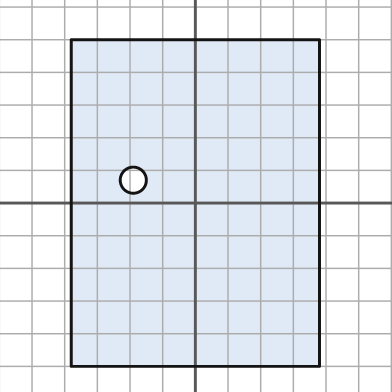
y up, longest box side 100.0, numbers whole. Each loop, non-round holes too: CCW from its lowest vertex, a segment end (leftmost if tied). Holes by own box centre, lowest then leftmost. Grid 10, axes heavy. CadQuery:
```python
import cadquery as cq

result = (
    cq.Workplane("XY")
    .moveTo(-38.0, -50.0)
    .lineTo(38.0, -50.0)
    .lineTo(38.0, 50.0)
    .lineTo(-38.0, 50.0)
    .close()
    .moveTo(-19.0, 7.0)
    .circle(4.0)
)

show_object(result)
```